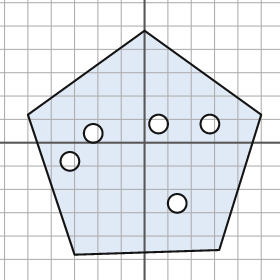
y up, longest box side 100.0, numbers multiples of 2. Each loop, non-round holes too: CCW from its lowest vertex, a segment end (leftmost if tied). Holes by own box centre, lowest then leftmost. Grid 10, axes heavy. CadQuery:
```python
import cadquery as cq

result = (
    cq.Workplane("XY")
    .moveTo(-30.0, -48.0)
    .lineTo(32.0, -46.0)
    .lineTo(50.0, 12.0)
    .lineTo(0.0, 48.0)
    .lineTo(-50.0, 12.0)
    .close()
    .moveTo(14.0, -26.0)
    .circle(4.0)
    .moveTo(-32.0, -8.0)
    .circle(4.0)
    .moveTo(-22.0, 4.0)
    .circle(4.0)
    .moveTo(6.0, 8.0)
    .circle(4.0)
    .moveTo(28.0, 8.0)
    .circle(4.0)
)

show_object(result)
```